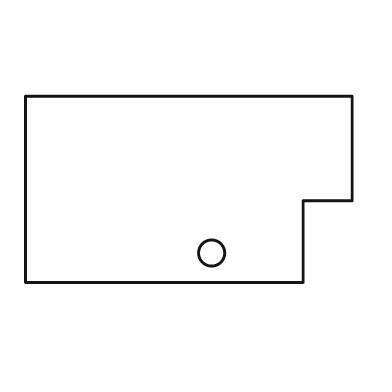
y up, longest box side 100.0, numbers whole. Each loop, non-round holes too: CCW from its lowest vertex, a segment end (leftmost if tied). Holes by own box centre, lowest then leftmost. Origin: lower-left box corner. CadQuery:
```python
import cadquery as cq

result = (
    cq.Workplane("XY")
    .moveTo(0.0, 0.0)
    .lineTo(85.0, 0.0)
    .lineTo(85.0, 25.0)
    .lineTo(100.0, 25.0)
    .lineTo(100.0, 57.0)
    .lineTo(0.0, 57.0)
    .close()
    .moveTo(57.0, 9.0)
    .circle(4.0)
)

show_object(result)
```